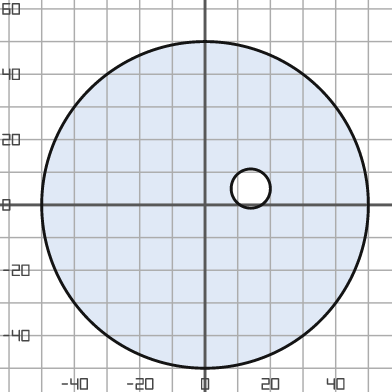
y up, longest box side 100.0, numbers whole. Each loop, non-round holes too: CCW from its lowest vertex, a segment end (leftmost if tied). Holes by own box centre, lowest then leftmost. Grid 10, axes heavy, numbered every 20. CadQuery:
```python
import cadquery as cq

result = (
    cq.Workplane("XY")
    .moveTo(0.0, 0.0)
    .circle(50.0)
    .moveTo(14.0, 5.0)
    .circle(6.0)
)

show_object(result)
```